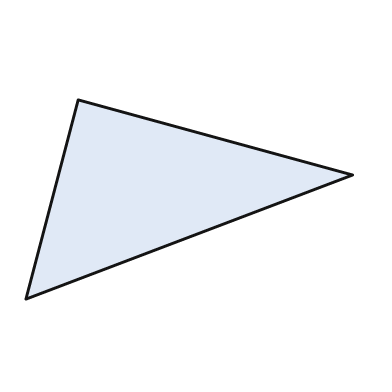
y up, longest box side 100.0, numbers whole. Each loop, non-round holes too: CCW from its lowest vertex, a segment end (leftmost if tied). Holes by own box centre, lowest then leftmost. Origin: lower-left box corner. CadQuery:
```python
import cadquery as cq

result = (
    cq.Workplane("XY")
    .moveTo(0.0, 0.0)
    .lineTo(100.0, 38.0)
    .lineTo(16.0, 61.0)
    .close()
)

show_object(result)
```